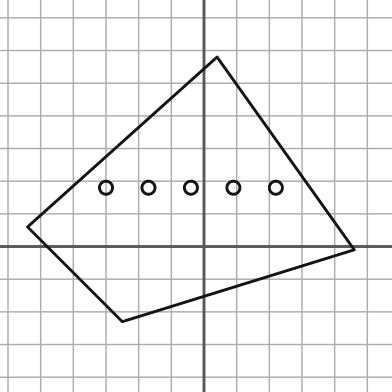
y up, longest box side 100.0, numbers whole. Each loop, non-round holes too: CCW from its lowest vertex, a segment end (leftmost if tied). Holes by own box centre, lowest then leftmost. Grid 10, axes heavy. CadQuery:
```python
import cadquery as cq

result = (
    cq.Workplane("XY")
    .moveTo(-25.0, -23.0)
    .lineTo(46.0, -1.0)
    .lineTo(4.0, 58.0)
    .lineTo(-54.0, 6.0)
    .close()
    .moveTo(-30.0, 18.0)
    .circle(2.0)
    .moveTo(-17.0, 18.0)
    .circle(2.0)
    .moveTo(-4.0, 18.0)
    .circle(2.0)
    .moveTo(9.0, 18.0)
    .circle(2.0)
    .moveTo(22.0, 18.0)
    .circle(2.0)
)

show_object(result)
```